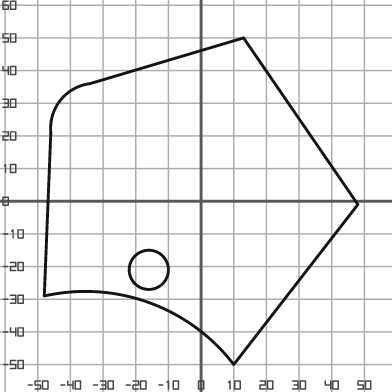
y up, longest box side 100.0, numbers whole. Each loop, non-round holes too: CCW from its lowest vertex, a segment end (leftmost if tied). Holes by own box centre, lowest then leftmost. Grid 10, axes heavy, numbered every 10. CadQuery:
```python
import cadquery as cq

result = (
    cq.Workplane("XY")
    .moveTo(10.0, -50.0)
    .lineTo(48.0, -1.0)
    .lineTo(13.0, 50.0)
    .lineTo(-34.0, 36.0)
    .threePointArc((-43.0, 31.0), (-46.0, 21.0))
    .lineTo(-48.0, -29.0)
    .threePointArc((-16.0, -31.0), (10.0, -50.0))
    .close()
    .moveTo(-16.0, -21.0)
    .circle(6.0)
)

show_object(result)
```